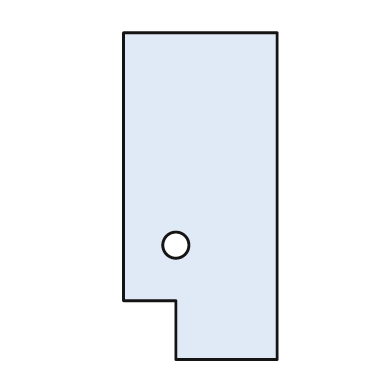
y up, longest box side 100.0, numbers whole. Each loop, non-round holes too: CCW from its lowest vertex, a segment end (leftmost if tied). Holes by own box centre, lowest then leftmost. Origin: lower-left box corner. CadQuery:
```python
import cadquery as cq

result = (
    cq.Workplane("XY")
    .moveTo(16.0, 0.0)
    .lineTo(47.0, 0.0)
    .lineTo(47.0, 100.0)
    .lineTo(0.0, 100.0)
    .lineTo(0.0, 18.0)
    .lineTo(16.0, 18.0)
    .close()
    .moveTo(16.0, 35.0)
    .circle(4.0)
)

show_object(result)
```